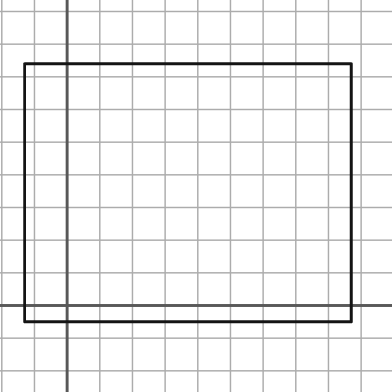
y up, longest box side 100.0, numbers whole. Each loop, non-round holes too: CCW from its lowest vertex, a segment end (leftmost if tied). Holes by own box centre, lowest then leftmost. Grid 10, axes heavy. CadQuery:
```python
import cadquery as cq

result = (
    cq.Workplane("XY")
    .moveTo(-13.0, -5.0)
    .lineTo(87.0, -5.0)
    .lineTo(87.0, 74.0)
    .lineTo(-13.0, 74.0)
    .close()
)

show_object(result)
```